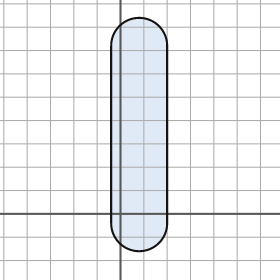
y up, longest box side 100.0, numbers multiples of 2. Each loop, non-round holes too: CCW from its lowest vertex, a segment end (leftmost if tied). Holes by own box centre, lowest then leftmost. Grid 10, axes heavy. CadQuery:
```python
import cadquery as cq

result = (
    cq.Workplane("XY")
    .moveTo(-4.0, -4.0)
    .threePointArc((8.0, -16.0), (20.0, -4.0))
    .lineTo(20.0, 72.0)
    .threePointArc((8.0, 84.0), (-4.0, 72.0))
    .close()
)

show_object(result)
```